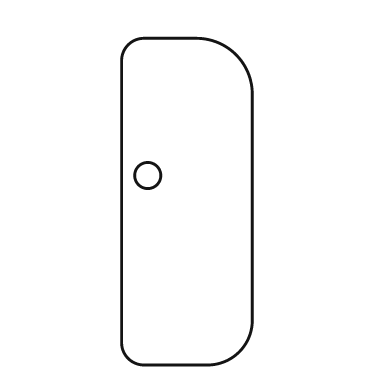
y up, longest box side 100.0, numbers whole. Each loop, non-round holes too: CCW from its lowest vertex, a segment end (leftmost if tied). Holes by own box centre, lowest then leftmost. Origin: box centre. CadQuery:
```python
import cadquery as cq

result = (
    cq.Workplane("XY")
    .moveTo(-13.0, -50.0)
    .lineTo(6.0, -50.0)
    .threePointArc((16.0, -46.0), (20.0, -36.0))
    .lineTo(20.0, 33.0)
    .threePointArc((15.0, 45.0), (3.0, 50.0))
    .lineTo(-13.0, 50.0)
    .threePointArc((-18.0, 48.0), (-20.0, 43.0))
    .lineTo(-20.0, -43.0)
    .threePointArc((-18.0, -48.0), (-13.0, -50.0))
    .close()
    .moveTo(-12.0, 8.0)
    .circle(4.0)
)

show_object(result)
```